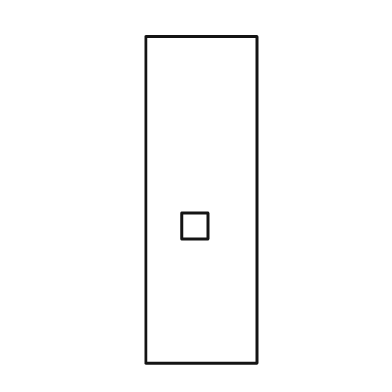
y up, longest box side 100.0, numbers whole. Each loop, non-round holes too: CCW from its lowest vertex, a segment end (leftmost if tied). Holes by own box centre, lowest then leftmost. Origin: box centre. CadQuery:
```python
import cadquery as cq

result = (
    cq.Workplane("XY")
    .moveTo(-17.0, -50.0)
    .lineTo(17.0, -50.0)
    .lineTo(17.0, 50.0)
    .lineTo(-17.0, 50.0)
    .close()
    .moveTo(-6.0, -12.0)
    .lineTo(2.0, -12.0)
    .lineTo(2.0, -4.0)
    .lineTo(-6.0, -4.0)
    .close()
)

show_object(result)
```